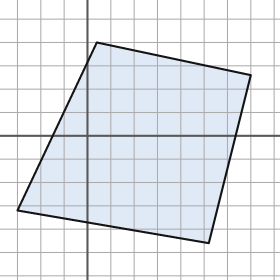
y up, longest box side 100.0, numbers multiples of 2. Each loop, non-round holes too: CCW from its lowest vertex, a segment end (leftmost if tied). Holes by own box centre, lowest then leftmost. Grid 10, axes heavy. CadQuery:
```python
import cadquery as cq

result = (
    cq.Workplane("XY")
    .moveTo(52.0, -46.0)
    .lineTo(70.0, 26.0)
    .lineTo(4.0, 40.0)
    .lineTo(-30.0, -32.0)
    .close()
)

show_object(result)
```